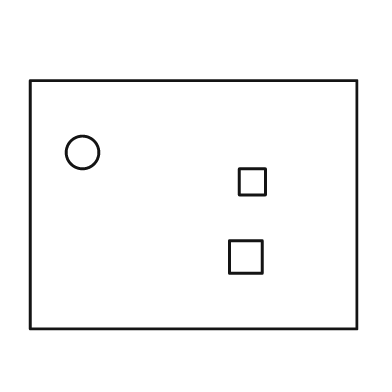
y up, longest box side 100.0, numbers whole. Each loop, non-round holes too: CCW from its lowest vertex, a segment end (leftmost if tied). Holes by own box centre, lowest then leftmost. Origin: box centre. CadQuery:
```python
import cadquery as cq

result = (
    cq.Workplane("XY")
    .moveTo(-50.0, -38.0)
    .lineTo(50.0, -38.0)
    .lineTo(50.0, 38.0)
    .lineTo(-50.0, 38.0)
    .close()
    .moveTo(11.0, -21.0)
    .lineTo(21.0, -21.0)
    .lineTo(21.0, -11.0)
    .lineTo(11.0, -11.0)
    .close()
    .moveTo(14.0, 3.0)
    .lineTo(22.0, 3.0)
    .lineTo(22.0, 11.0)
    .lineTo(14.0, 11.0)
    .close()
    .moveTo(-34.0, 16.0)
    .circle(5.0)
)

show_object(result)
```